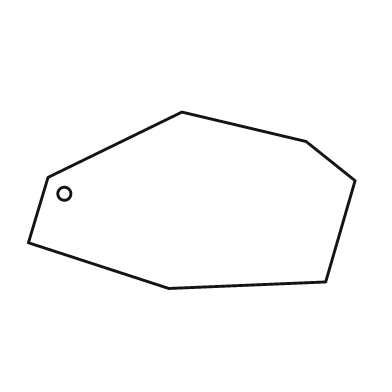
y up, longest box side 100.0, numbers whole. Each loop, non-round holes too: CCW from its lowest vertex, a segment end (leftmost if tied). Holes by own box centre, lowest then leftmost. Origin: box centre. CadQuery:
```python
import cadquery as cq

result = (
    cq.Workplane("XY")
    .moveTo(-7.0, -27.0)
    .lineTo(41.0, -25.0)
    .lineTo(50.0, 6.0)
    .lineTo(35.0, 18.0)
    .lineTo(-3.0, 27.0)
    .lineTo(-44.0, 7.0)
    .lineTo(-50.0, -13.0)
    .close()
    .moveTo(-39.0, 2.0)
    .circle(2.0)
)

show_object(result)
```